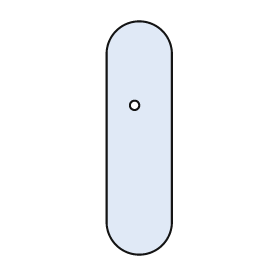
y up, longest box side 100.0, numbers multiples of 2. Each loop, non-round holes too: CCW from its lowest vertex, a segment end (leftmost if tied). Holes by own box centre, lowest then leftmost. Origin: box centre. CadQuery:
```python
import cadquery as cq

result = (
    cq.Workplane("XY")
    .moveTo(-14.0, -36.0)
    .threePointArc((0.0, -50.0), (14.0, -36.0))
    .lineTo(14.0, 36.0)
    .threePointArc((0.0, 50.0), (-14.0, 36.0))
    .close()
    .moveTo(-2.0, 14.0)
    .circle(2.0)
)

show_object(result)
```